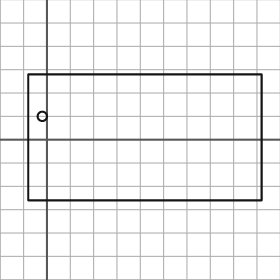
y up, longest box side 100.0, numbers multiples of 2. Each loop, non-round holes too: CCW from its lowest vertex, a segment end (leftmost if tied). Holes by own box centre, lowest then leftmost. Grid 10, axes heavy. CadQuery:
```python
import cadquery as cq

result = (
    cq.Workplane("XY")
    .moveTo(-8.0, -26.0)
    .lineTo(92.0, -26.0)
    .lineTo(92.0, 28.0)
    .lineTo(-8.0, 28.0)
    .close()
    .moveTo(-2.0, 10.0)
    .circle(2.0)
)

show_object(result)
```